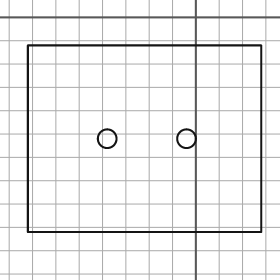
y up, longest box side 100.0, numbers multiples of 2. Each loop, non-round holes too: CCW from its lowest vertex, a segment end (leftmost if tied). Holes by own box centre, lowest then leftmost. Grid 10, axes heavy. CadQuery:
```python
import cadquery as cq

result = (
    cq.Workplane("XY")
    .moveTo(-72.0, -92.0)
    .lineTo(28.0, -92.0)
    .lineTo(28.0, -12.0)
    .lineTo(-72.0, -12.0)
    .close()
    .moveTo(-38.0, -52.0)
    .circle(4.0)
    .moveTo(-4.0, -52.0)
    .circle(4.0)
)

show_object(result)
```